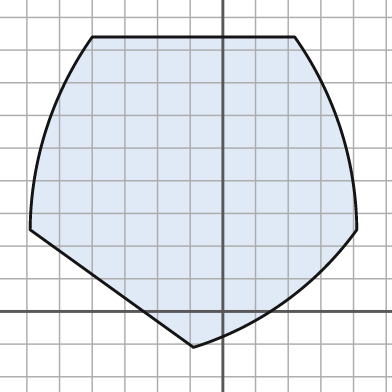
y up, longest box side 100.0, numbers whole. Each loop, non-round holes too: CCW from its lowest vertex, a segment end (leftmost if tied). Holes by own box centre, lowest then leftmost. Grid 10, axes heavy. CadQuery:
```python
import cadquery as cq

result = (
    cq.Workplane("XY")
    .moveTo(-9.0, -11.0)
    .threePointArc((19.0, 3.0), (41.0, 25.0))
    .threePointArc((36.0, 56.0), (22.0, 84.0))
    .lineTo(-40.0, 84.0)
    .threePointArc((-54.0, 56.0), (-59.0, 25.0))
    .close()
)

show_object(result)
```